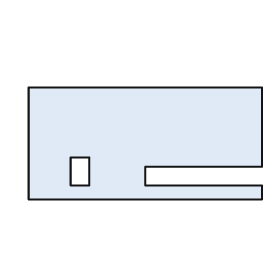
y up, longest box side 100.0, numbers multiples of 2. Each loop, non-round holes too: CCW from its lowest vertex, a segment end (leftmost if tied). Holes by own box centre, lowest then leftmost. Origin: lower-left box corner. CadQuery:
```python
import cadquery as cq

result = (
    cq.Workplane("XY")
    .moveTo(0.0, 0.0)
    .lineTo(100.0, 0.0)
    .lineTo(100.0, 6.0)
    .lineTo(50.0, 6.0)
    .lineTo(50.0, 14.0)
    .lineTo(100.0, 14.0)
    .lineTo(100.0, 48.0)
    .lineTo(0.0, 48.0)
    .close()
    .moveTo(18.0, 6.0)
    .lineTo(26.0, 6.0)
    .lineTo(26.0, 18.0)
    .lineTo(18.0, 18.0)
    .close()
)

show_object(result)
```